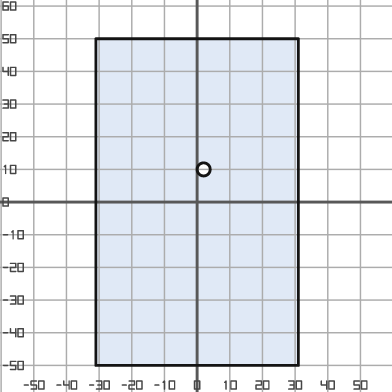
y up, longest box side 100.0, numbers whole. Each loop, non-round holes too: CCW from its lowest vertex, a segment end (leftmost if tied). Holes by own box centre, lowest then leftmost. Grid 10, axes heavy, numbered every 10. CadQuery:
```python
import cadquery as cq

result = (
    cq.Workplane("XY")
    .moveTo(-31.0, -50.0)
    .lineTo(31.0, -50.0)
    .lineTo(31.0, 50.0)
    .lineTo(-31.0, 50.0)
    .close()
    .moveTo(2.0, 10.0)
    .circle(2.0)
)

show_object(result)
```